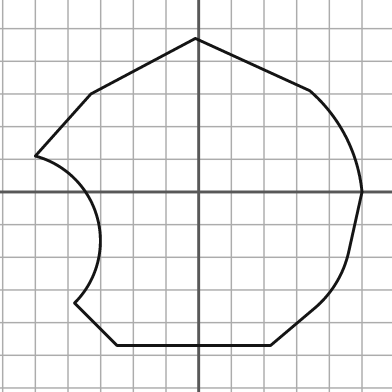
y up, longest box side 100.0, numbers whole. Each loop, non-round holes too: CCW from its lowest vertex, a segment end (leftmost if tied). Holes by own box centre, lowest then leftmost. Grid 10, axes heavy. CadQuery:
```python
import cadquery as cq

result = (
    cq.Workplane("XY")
    .moveTo(-25.0, -47.0)
    .lineTo(22.0, -47.0)
    .lineTo(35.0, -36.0)
    .threePointArc((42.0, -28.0), (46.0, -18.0))
    .lineTo(50.0, 0.0)
    .threePointArc((45.0, 17.0), (34.0, 31.0))
    .lineTo(-1.0, 47.0)
    .lineTo(-33.0, 30.0)
    .lineTo(-50.0, 11.0)
    .threePointArc((-31.0, -8.0), (-38.0, -34.0))
    .close()
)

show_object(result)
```